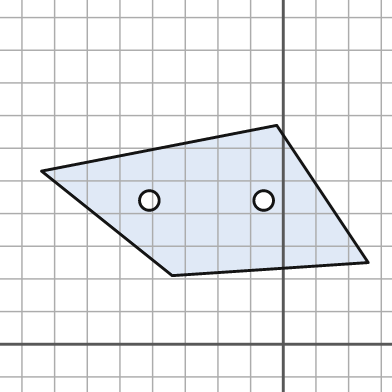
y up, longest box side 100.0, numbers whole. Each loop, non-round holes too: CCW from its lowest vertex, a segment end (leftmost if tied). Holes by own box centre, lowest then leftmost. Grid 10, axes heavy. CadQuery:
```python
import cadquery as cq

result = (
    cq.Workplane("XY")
    .moveTo(-34.0, 21.0)
    .lineTo(26.0, 25.0)
    .lineTo(-2.0, 67.0)
    .lineTo(-74.0, 53.0)
    .close()
    .moveTo(-41.0, 44.0)
    .circle(3.0)
    .moveTo(-6.0, 44.0)
    .circle(3.0)
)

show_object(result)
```